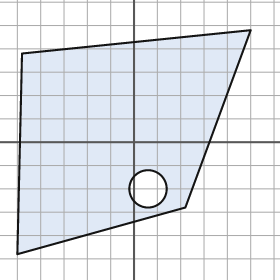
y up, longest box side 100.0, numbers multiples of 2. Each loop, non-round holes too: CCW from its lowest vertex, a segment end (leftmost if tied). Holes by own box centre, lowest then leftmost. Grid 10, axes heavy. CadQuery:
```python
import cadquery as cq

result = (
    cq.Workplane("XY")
    .moveTo(-50.0, -48.0)
    .lineTo(22.0, -28.0)
    .lineTo(50.0, 48.0)
    .lineTo(-48.0, 38.0)
    .close()
    .moveTo(6.0, -20.0)
    .circle(8.0)
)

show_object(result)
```